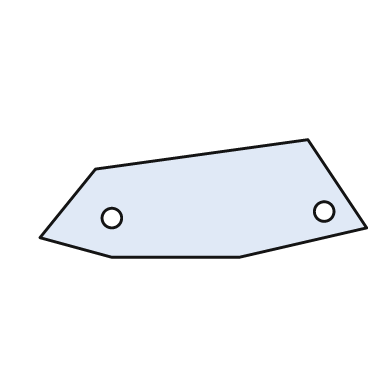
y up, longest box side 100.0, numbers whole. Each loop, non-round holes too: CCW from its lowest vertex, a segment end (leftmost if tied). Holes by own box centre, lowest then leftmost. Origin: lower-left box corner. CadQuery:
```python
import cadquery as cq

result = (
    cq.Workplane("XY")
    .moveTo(22.0, 0.0)
    .lineTo(61.0, 0.0)
    .lineTo(100.0, 9.0)
    .lineTo(82.0, 36.0)
    .lineTo(17.0, 27.0)
    .lineTo(0.0, 6.0)
    .close()
    .moveTo(22.0, 12.0)
    .circle(3.0)
    .moveTo(87.0, 14.0)
    .circle(3.0)
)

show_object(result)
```